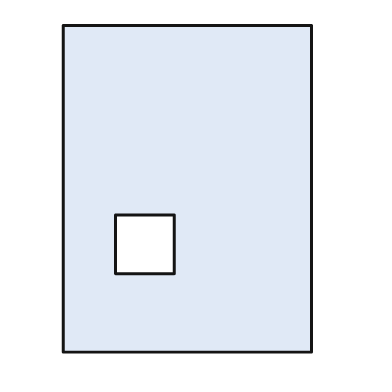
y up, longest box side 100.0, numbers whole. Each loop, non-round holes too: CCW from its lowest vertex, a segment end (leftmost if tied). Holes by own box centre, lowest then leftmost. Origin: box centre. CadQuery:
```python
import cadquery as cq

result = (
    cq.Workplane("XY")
    .moveTo(-38.0, -50.0)
    .lineTo(38.0, -50.0)
    .lineTo(38.0, 50.0)
    .lineTo(-38.0, 50.0)
    .close()
    .moveTo(-22.0, -26.0)
    .lineTo(-4.0, -26.0)
    .lineTo(-4.0, -8.0)
    .lineTo(-22.0, -8.0)
    .close()
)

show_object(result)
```